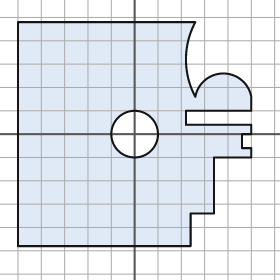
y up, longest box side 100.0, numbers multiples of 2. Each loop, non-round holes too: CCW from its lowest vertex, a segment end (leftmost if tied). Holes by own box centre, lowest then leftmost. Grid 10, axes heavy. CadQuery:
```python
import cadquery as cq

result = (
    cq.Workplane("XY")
    .moveTo(-50.0, -48.0)
    .lineTo(24.0, -48.0)
    .lineTo(24.0, -34.0)
    .lineTo(34.0, -34.0)
    .lineTo(34.0, -10.0)
    .lineTo(50.0, -10.0)
    .lineTo(50.0, -6.0)
    .lineTo(46.0, -6.0)
    .lineTo(46.0, 0.0)
    .lineTo(50.0, 0.0)
    .lineTo(50.0, 4.0)
    .lineTo(22.0, 4.0)
    .lineTo(22.0, 10.0)
    .lineTo(50.0, 10.0)
    .lineTo(50.0, 16.0)
    .threePointArc((38.0, 26.0), (26.0, 16.0))
    .threePointArc((22.0, 32.0), (26.0, 48.0))
    .lineTo(-50.0, 48.0)
    .close()
    .moveTo(0.0, 0.0)
    .circle(10.0)
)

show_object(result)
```